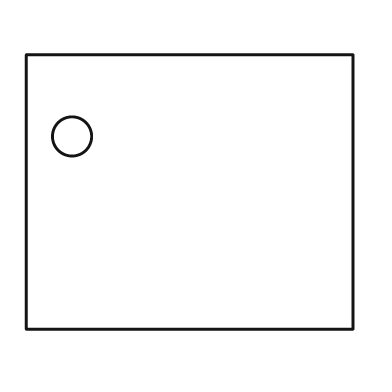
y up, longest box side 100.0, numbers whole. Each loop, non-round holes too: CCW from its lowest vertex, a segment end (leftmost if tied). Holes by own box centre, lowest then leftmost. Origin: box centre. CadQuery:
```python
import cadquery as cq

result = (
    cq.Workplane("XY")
    .moveTo(-50.0, -42.0)
    .lineTo(50.0, -42.0)
    .lineTo(50.0, 42.0)
    .lineTo(-50.0, 42.0)
    .close()
    .moveTo(-36.0, 17.0)
    .circle(6.0)
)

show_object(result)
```